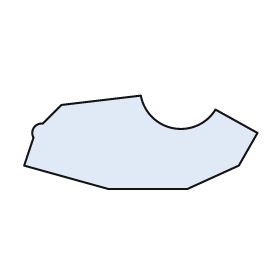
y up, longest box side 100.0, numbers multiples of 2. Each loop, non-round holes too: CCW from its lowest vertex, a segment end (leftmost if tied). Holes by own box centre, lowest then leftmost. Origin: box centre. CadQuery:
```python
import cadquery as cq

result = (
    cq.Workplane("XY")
    .moveTo(-14.0, -20.0)
    .lineTo(20.0, -20.0)
    .lineTo(42.0, -10.0)
    .lineTo(50.0, 4.0)
    .lineTo(32.0, 14.0)
    .threePointArc((14.0, 6.0), (0.0, 20.0))
    .lineTo(-34.0, 16.0)
    .lineTo(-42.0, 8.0)
    .threePointArc((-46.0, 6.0), (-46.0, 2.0))
    .lineTo(-50.0, -10.0)
    .close()
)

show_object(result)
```